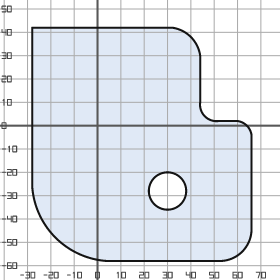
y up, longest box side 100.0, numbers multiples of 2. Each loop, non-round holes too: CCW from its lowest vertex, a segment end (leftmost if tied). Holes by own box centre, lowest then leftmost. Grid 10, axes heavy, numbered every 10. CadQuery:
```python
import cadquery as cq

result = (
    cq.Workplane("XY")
    .moveTo(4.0, -58.0)
    .lineTo(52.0, -58.0)
    .threePointArc((62.0, -54.0), (66.0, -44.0))
    .lineTo(66.0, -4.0)
    .threePointArc((64.0, 0.0), (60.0, 2.0))
    .lineTo(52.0, 2.0)
    .threePointArc((46.0, 4.0), (44.0, 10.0))
    .lineTo(44.0, 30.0)
    .threePointArc((40.0, 38.0), (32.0, 42.0))
    .lineTo(-28.0, 42.0)
    .lineTo(-28.0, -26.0)
    .threePointArc((-18.0, -48.0), (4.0, -58.0))
    .close()
    .moveTo(30.0, -28.0)
    .circle(8.0)
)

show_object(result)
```